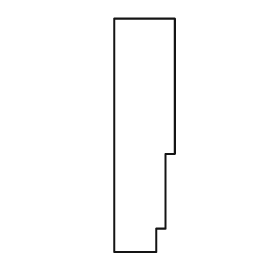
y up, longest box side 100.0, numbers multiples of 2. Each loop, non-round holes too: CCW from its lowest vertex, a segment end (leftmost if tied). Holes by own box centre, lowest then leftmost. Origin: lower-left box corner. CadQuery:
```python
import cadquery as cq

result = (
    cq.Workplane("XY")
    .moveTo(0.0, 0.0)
    .lineTo(18.0, 0.0)
    .lineTo(18.0, 10.0)
    .lineTo(22.0, 10.0)
    .lineTo(22.0, 42.0)
    .lineTo(26.0, 42.0)
    .lineTo(26.0, 100.0)
    .lineTo(0.0, 100.0)
    .close()
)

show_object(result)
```